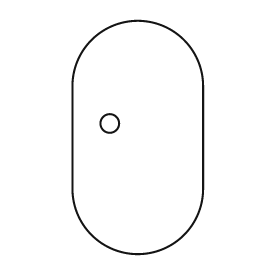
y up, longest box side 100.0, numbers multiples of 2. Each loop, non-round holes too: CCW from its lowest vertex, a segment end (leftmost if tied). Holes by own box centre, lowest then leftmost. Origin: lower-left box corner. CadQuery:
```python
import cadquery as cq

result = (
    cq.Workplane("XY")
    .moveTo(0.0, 28.0)
    .threePointArc((28.0, 0.0), (56.0, 28.0))
    .lineTo(56.0, 72.0)
    .threePointArc((28.0, 100.0), (0.0, 72.0))
    .close()
    .moveTo(16.0, 56.0)
    .circle(4.0)
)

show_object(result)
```